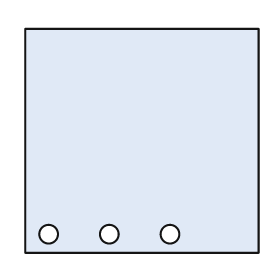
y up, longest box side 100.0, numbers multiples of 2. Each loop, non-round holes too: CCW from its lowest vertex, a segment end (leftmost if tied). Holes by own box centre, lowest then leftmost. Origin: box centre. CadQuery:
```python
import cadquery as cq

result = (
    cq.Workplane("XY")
    .moveTo(-50.0, -48.0)
    .lineTo(50.0, -48.0)
    .lineTo(50.0, 48.0)
    .lineTo(-50.0, 48.0)
    .close()
    .moveTo(-40.0, -40.0)
    .circle(4.0)
    .moveTo(-14.0, -40.0)
    .circle(4.0)
    .moveTo(12.0, -40.0)
    .circle(4.0)
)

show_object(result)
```